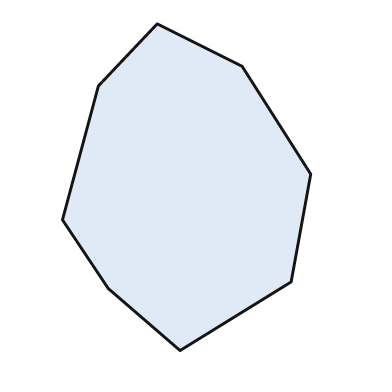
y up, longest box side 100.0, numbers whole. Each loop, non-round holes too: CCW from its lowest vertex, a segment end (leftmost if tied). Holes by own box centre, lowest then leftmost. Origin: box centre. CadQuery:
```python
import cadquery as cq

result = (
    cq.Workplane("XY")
    .moveTo(-2.0, -50.0)
    .lineTo(32.0, -29.0)
    .lineTo(38.0, 4.0)
    .lineTo(17.0, 37.0)
    .lineTo(-9.0, 50.0)
    .lineTo(-27.0, 31.0)
    .lineTo(-38.0, -10.0)
    .lineTo(-24.0, -31.0)
    .close()
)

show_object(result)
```